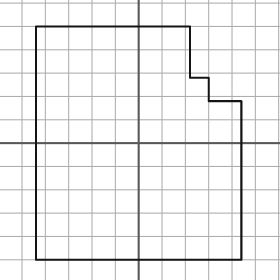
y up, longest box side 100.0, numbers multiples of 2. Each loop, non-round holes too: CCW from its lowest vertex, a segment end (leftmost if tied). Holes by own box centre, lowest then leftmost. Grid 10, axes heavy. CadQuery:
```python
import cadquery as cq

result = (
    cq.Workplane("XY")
    .moveTo(-44.0, -50.0)
    .lineTo(44.0, -50.0)
    .lineTo(44.0, 18.0)
    .lineTo(30.0, 18.0)
    .lineTo(30.0, 28.0)
    .lineTo(22.0, 28.0)
    .lineTo(22.0, 50.0)
    .lineTo(-44.0, 50.0)
    .close()
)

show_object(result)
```